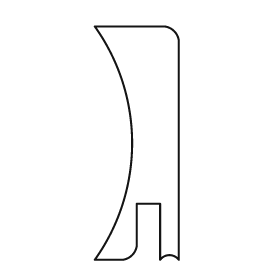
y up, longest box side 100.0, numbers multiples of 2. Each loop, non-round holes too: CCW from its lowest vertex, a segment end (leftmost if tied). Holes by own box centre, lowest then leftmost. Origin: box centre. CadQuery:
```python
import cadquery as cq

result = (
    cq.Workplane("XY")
    .moveTo(-18.0, -50.0)
    .lineTo(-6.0, -50.0)
    .threePointArc((-2.0, -48.0), (0.0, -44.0))
    .lineTo(0.0, -26.0)
    .lineTo(10.0, -26.0)
    .lineTo(10.0, -50.0)
    .threePointArc((14.0, -48.0), (18.0, -50.0))
    .lineTo(18.0, 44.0)
    .threePointArc((16.0, 48.0), (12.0, 50.0))
    .lineTo(-18.0, 50.0)
    .threePointArc((-2.0, 0.0), (-18.0, -50.0))
    .close()
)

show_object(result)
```